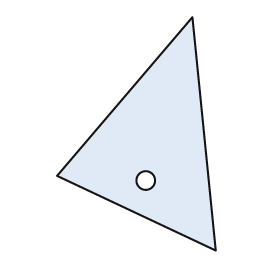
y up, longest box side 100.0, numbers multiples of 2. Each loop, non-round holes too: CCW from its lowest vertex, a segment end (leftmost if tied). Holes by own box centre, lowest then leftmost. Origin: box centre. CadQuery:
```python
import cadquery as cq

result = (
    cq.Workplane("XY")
    .moveTo(34.0, -50.0)
    .lineTo(24.0, 50.0)
    .lineTo(-34.0, -18.0)
    .close()
    .moveTo(4.0, -20.0)
    .circle(4.0)
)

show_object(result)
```